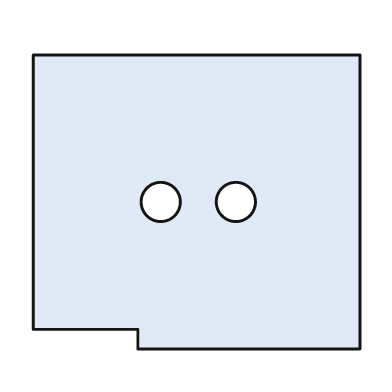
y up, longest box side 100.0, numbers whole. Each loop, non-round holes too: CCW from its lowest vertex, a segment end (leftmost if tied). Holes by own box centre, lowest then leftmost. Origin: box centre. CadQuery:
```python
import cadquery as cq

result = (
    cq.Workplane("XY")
    .moveTo(-18.0, -45.0)
    .lineTo(50.0, -45.0)
    .lineTo(50.0, 45.0)
    .lineTo(-50.0, 45.0)
    .lineTo(-50.0, -39.0)
    .lineTo(-18.0, -39.0)
    .close()
    .moveTo(-11.0, 0.0)
    .circle(6.0)
    .moveTo(12.0, 0.0)
    .circle(6.0)
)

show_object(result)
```